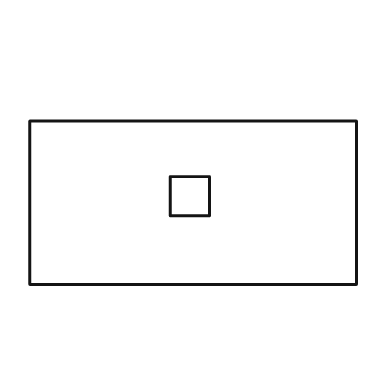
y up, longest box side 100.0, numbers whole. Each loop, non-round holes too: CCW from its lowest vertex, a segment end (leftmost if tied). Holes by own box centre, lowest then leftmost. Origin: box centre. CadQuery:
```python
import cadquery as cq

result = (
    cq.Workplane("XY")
    .moveTo(-50.0, -25.0)
    .lineTo(50.0, -25.0)
    .lineTo(50.0, 25.0)
    .lineTo(-50.0, 25.0)
    .close()
    .moveTo(-7.0, -4.0)
    .lineTo(5.0, -4.0)
    .lineTo(5.0, 8.0)
    .lineTo(-7.0, 8.0)
    .close()
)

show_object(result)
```